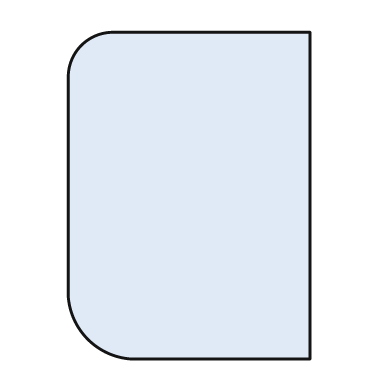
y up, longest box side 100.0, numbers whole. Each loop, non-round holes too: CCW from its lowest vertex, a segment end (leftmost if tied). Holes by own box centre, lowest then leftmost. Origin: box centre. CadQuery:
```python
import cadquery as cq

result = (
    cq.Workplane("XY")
    .moveTo(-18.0, -50.0)
    .lineTo(37.0, -50.0)
    .lineTo(37.0, 50.0)
    .lineTo(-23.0, 50.0)
    .threePointArc((-33.0, 46.0), (-37.0, 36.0))
    .lineTo(-37.0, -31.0)
    .threePointArc((-31.0, -44.0), (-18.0, -50.0))
    .close()
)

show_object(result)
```